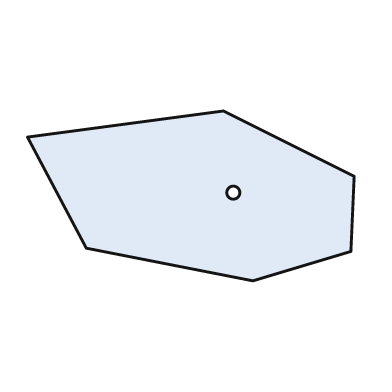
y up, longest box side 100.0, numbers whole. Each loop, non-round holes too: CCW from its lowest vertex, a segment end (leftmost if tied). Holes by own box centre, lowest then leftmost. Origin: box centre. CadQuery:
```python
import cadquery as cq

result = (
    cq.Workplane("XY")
    .moveTo(19.0, -26.0)
    .lineTo(49.0, -17.0)
    .lineTo(50.0, 6.0)
    .lineTo(10.0, 26.0)
    .lineTo(-50.0, 18.0)
    .lineTo(-32.0, -16.0)
    .close()
    .moveTo(13.0, 1.0)
    .circle(2.0)
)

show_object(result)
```